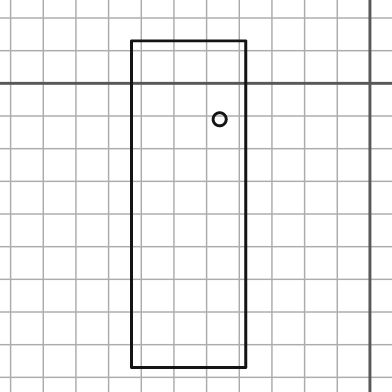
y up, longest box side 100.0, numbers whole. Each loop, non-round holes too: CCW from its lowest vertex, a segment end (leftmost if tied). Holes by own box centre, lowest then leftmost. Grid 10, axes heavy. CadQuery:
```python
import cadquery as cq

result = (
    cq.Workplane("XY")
    .moveTo(-73.0, -87.0)
    .lineTo(-38.0, -87.0)
    .lineTo(-38.0, 13.0)
    .lineTo(-73.0, 13.0)
    .close()
    .moveTo(-46.0, -11.0)
    .circle(2.0)
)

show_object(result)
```